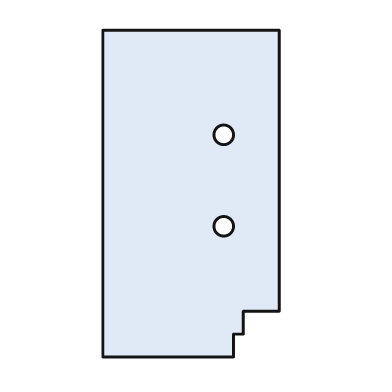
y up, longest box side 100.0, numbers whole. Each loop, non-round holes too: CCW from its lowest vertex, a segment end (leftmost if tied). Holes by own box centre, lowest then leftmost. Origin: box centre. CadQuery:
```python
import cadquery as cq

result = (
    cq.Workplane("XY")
    .moveTo(-27.0, -50.0)
    .lineTo(13.0, -50.0)
    .lineTo(13.0, -43.0)
    .lineTo(16.0, -43.0)
    .lineTo(16.0, -36.0)
    .lineTo(27.0, -36.0)
    .lineTo(27.0, 50.0)
    .lineTo(-27.0, 50.0)
    .close()
    .moveTo(10.0, -10.0)
    .circle(3.0)
    .moveTo(10.0, 18.0)
    .circle(3.0)
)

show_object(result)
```